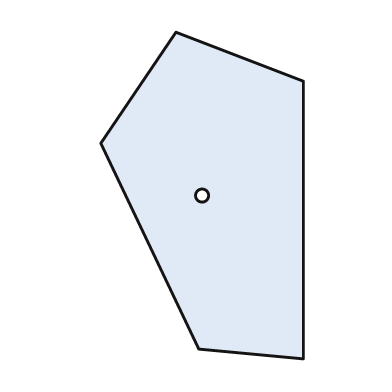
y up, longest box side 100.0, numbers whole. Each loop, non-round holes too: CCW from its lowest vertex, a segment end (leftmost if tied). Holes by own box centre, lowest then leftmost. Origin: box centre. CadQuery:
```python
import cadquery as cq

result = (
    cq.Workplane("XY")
    .moveTo(31.0, -50.0)
    .lineTo(31.0, 35.0)
    .lineTo(-8.0, 50.0)
    .lineTo(-31.0, 16.0)
    .lineTo(-1.0, -47.0)
    .close()
    .moveTo(0.0, 0.0)
    .circle(2.0)
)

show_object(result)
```